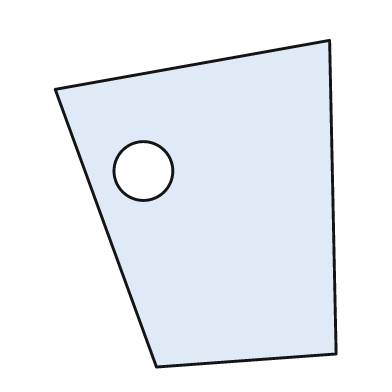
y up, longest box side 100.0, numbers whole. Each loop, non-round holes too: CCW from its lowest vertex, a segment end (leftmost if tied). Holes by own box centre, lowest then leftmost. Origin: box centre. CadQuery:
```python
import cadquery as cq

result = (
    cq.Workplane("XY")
    .moveTo(-12.0, -50.0)
    .lineTo(43.0, -46.0)
    .lineTo(41.0, 50.0)
    .lineTo(-43.0, 35.0)
    .close()
    .moveTo(-16.0, 10.0)
    .circle(9.0)
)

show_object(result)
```